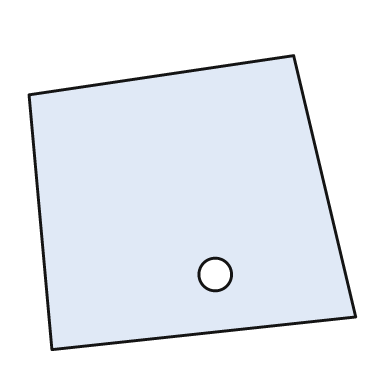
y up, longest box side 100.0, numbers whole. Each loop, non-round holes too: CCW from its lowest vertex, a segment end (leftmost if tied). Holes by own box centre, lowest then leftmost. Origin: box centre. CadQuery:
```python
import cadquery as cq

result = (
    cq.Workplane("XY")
    .moveTo(-43.0, -45.0)
    .lineTo(50.0, -35.0)
    .lineTo(31.0, 45.0)
    .lineTo(-50.0, 33.0)
    .close()
    .moveTo(7.0, -22.0)
    .circle(5.0)
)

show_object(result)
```